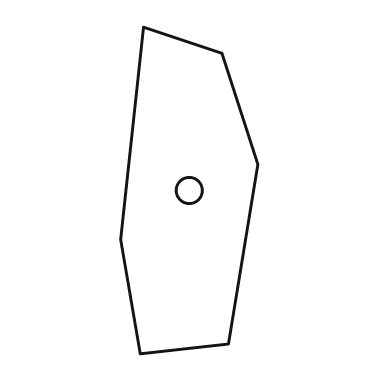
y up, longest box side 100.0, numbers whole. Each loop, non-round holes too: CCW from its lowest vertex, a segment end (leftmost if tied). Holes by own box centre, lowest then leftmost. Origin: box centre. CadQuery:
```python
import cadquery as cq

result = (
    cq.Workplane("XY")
    .moveTo(-15.0, -50.0)
    .lineTo(12.0, -47.0)
    .lineTo(21.0, 8.0)
    .lineTo(10.0, 42.0)
    .lineTo(-14.0, 50.0)
    .lineTo(-21.0, -15.0)
    .close()
    .moveTo(0.0, 0.0)
    .circle(4.0)
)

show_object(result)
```